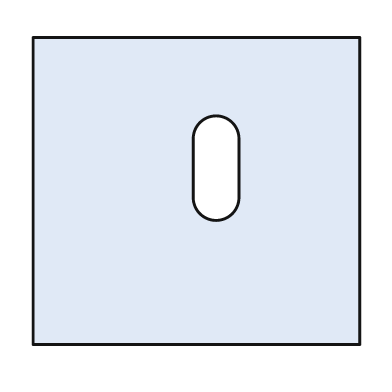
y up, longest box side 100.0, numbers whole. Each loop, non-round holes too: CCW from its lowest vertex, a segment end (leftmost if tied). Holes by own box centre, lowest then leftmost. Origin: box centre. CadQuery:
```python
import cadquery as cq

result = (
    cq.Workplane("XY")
    .moveTo(-50.0, -47.0)
    .lineTo(50.0, -47.0)
    .lineTo(50.0, 47.0)
    .lineTo(-50.0, 47.0)
    .close()
    .moveTo(-1.0, -2.0)
    .threePointArc((6.0, -9.0), (13.0, -2.0))
    .lineTo(13.0, 16.0)
    .threePointArc((6.0, 23.0), (-1.0, 16.0))
    .close()
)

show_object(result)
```